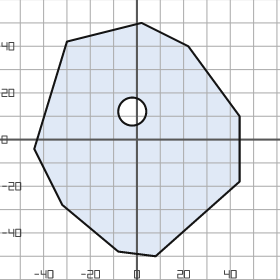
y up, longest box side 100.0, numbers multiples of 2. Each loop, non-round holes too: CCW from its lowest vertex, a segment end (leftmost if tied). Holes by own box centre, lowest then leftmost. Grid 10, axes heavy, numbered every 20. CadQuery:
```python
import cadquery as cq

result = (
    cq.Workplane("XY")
    .moveTo(8.0, -50.0)
    .lineTo(44.0, -18.0)
    .lineTo(44.0, 10.0)
    .lineTo(22.0, 40.0)
    .lineTo(2.0, 50.0)
    .lineTo(-30.0, 42.0)
    .lineTo(-44.0, -4.0)
    .lineTo(-32.0, -28.0)
    .lineTo(-8.0, -48.0)
    .close()
    .moveTo(-2.0, 12.0)
    .circle(6.0)
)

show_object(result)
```